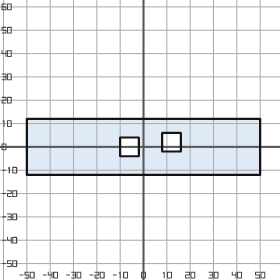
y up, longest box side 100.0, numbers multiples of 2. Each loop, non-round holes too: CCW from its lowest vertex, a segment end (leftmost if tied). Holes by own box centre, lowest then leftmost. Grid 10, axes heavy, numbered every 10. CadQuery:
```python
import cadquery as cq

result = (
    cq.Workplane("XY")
    .moveTo(-50.0, -12.0)
    .lineTo(50.0, -12.0)
    .lineTo(50.0, 12.0)
    .lineTo(-50.0, 12.0)
    .close()
    .moveTo(-10.0, -4.0)
    .lineTo(-2.0, -4.0)
    .lineTo(-2.0, 4.0)
    .lineTo(-10.0, 4.0)
    .close()
    .moveTo(8.0, -2.0)
    .lineTo(16.0, -2.0)
    .lineTo(16.0, 6.0)
    .lineTo(8.0, 6.0)
    .close()
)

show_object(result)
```